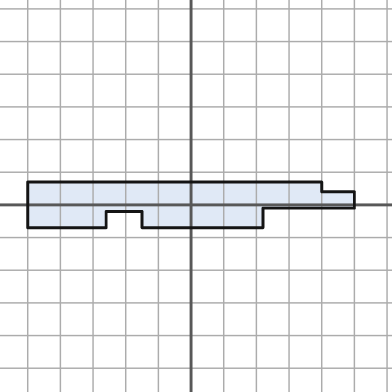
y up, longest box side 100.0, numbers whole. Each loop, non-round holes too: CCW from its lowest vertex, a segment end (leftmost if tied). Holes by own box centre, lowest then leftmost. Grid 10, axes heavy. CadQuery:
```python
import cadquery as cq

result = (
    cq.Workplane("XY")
    .moveTo(-50.0, -7.0)
    .lineTo(-26.0, -7.0)
    .lineTo(-26.0, -2.0)
    .lineTo(-15.0, -2.0)
    .lineTo(-15.0, -7.0)
    .lineTo(22.0, -7.0)
    .lineTo(22.0, -1.0)
    .lineTo(50.0, -1.0)
    .lineTo(50.0, 4.0)
    .lineTo(40.0, 4.0)
    .lineTo(40.0, 7.0)
    .lineTo(-50.0, 7.0)
    .close()
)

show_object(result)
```